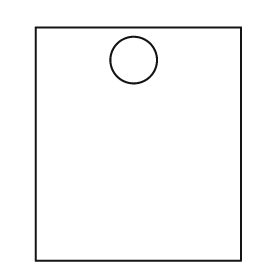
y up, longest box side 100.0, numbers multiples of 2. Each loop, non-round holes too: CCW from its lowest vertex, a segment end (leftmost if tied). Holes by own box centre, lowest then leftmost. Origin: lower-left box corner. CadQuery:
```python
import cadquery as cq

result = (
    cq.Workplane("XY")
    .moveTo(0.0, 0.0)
    .lineTo(88.0, 0.0)
    .lineTo(88.0, 100.0)
    .lineTo(0.0, 100.0)
    .close()
    .moveTo(42.0, 86.0)
    .circle(10.0)
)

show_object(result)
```